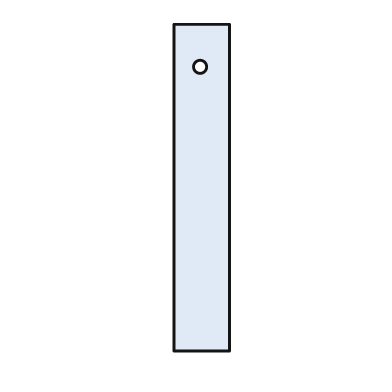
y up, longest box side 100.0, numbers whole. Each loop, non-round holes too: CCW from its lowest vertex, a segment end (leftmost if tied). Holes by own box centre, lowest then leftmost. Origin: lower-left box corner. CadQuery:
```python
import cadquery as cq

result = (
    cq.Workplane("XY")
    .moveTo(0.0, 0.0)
    .lineTo(17.0, 0.0)
    .lineTo(17.0, 100.0)
    .lineTo(0.0, 100.0)
    .close()
    .moveTo(8.0, 87.0)
    .circle(2.0)
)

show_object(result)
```